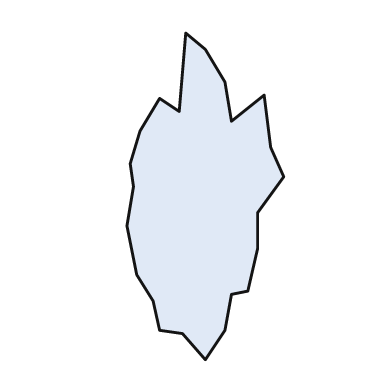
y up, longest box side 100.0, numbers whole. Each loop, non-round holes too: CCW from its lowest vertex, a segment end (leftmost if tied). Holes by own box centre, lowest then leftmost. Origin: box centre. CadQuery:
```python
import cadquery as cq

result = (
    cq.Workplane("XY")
    .moveTo(0.0, -50.0)
    .lineTo(6.0, -41.0)
    .lineTo(8.0, -30.0)
    .lineTo(13.0, -29.0)
    .lineTo(16.0, -16.0)
    .lineTo(16.0, -5.0)
    .lineTo(24.0, 6.0)
    .lineTo(20.0, 15.0)
    .lineTo(18.0, 31.0)
    .lineTo(8.0, 23.0)
    .lineTo(6.0, 35.0)
    .lineTo(0.0, 45.0)
    .lineTo(-6.0, 50.0)
    .lineTo(-8.0, 26.0)
    .lineTo(-14.0, 30.0)
    .lineTo(-20.0, 20.0)
    .lineTo(-23.0, 10.0)
    .lineTo(-22.0, 3.0)
    .lineTo(-24.0, -9.0)
    .lineTo(-21.0, -24.0)
    .lineTo(-16.0, -32.0)
    .lineTo(-14.0, -41.0)
    .lineTo(-7.0, -42.0)
    .close()
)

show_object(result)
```